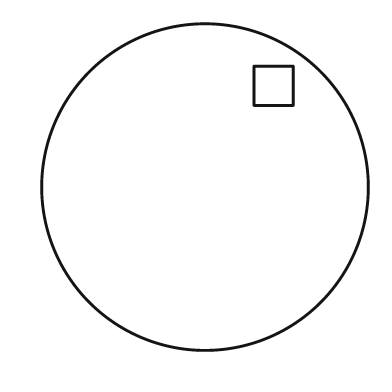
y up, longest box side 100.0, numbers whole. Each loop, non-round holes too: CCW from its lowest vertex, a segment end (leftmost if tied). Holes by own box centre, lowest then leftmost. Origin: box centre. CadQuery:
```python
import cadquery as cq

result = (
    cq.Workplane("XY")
    .moveTo(0.0, 0.0)
    .circle(50.0)
    .moveTo(15.0, 25.0)
    .lineTo(27.0, 25.0)
    .lineTo(27.0, 37.0)
    .lineTo(15.0, 37.0)
    .close()
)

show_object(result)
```